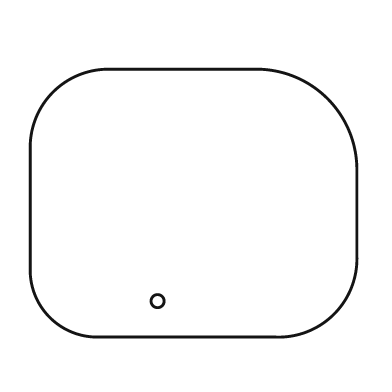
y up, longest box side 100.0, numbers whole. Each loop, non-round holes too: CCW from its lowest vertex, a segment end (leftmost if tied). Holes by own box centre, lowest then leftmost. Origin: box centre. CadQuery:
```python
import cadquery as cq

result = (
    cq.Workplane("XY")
    .moveTo(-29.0, -41.0)
    .lineTo(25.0, -41.0)
    .threePointArc((43.0, -34.0), (50.0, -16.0))
    .lineTo(50.0, 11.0)
    .threePointArc((41.0, 32.0), (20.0, 41.0))
    .lineTo(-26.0, 41.0)
    .threePointArc((-43.0, 34.0), (-50.0, 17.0))
    .lineTo(-50.0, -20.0)
    .threePointArc((-44.0, -35.0), (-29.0, -41.0))
    .close()
    .moveTo(-11.0, -30.0)
    .circle(2.0)
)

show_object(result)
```